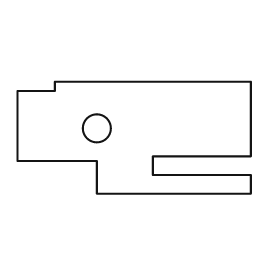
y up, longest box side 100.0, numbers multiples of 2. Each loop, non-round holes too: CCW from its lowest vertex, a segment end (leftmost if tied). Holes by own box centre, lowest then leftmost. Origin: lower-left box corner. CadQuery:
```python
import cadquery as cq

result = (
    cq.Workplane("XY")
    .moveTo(34.0, 0.0)
    .lineTo(100.0, 0.0)
    .lineTo(100.0, 8.0)
    .lineTo(58.0, 8.0)
    .lineTo(58.0, 16.0)
    .lineTo(100.0, 16.0)
    .lineTo(100.0, 48.0)
    .lineTo(16.0, 48.0)
    .lineTo(16.0, 44.0)
    .lineTo(0.0, 44.0)
    .lineTo(0.0, 14.0)
    .lineTo(34.0, 14.0)
    .close()
    .moveTo(34.0, 28.0)
    .circle(6.0)
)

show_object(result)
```